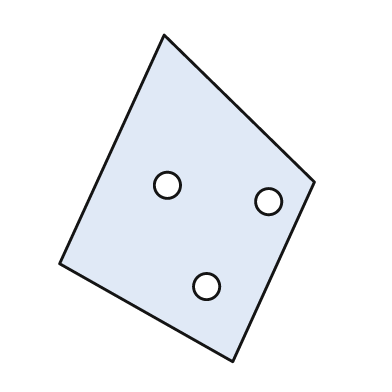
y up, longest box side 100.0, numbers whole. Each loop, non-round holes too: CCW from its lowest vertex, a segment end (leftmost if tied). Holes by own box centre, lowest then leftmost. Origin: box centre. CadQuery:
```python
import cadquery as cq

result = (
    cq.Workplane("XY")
    .moveTo(14.0, -50.0)
    .lineTo(39.0, 5.0)
    .lineTo(-7.0, 50.0)
    .lineTo(-39.0, -20.0)
    .close()
    .moveTo(6.0, -27.0)
    .circle(4.0)
    .moveTo(25.0, -1.0)
    .circle(4.0)
    .moveTo(-6.0, 4.0)
    .circle(4.0)
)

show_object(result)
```